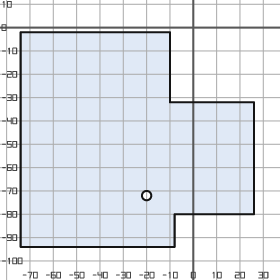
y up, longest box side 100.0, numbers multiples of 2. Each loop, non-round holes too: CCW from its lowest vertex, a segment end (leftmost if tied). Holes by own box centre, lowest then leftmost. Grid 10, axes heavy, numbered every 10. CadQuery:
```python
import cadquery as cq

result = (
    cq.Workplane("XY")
    .moveTo(-74.0, -94.0)
    .lineTo(-8.0, -94.0)
    .lineTo(-8.0, -80.0)
    .lineTo(26.0, -80.0)
    .lineTo(26.0, -32.0)
    .lineTo(-10.0, -32.0)
    .lineTo(-10.0, -2.0)
    .lineTo(-74.0, -2.0)
    .close()
    .moveTo(-20.0, -72.0)
    .circle(2.0)
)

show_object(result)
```